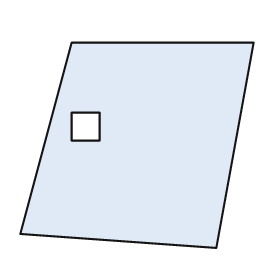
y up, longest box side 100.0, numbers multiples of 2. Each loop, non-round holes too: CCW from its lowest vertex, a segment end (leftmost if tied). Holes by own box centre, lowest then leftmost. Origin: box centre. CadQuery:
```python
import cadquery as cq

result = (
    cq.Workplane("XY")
    .moveTo(34.0, -44.0)
    .lineTo(50.0, 44.0)
    .lineTo(-28.0, 44.0)
    .lineTo(-50.0, -38.0)
    .close()
    .moveTo(-28.0, 2.0)
    .lineTo(-16.0, 2.0)
    .lineTo(-16.0, 14.0)
    .lineTo(-28.0, 14.0)
    .close()
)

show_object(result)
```